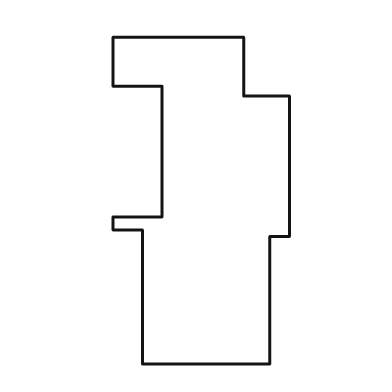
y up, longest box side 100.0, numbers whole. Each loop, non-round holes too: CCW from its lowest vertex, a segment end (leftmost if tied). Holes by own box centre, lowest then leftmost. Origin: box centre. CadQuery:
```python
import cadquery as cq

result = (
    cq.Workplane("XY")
    .moveTo(-18.0, -50.0)
    .lineTo(21.0, -50.0)
    .lineTo(21.0, -11.0)
    .lineTo(27.0, -11.0)
    .lineTo(27.0, 32.0)
    .lineTo(13.0, 32.0)
    .lineTo(13.0, 50.0)
    .lineTo(-27.0, 50.0)
    .lineTo(-27.0, 35.0)
    .lineTo(-12.0, 35.0)
    .lineTo(-12.0, -5.0)
    .lineTo(-27.0, -5.0)
    .lineTo(-27.0, -9.0)
    .lineTo(-18.0, -9.0)
    .close()
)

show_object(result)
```